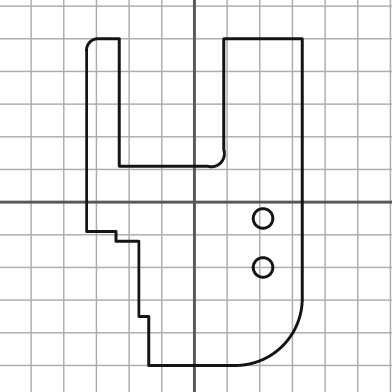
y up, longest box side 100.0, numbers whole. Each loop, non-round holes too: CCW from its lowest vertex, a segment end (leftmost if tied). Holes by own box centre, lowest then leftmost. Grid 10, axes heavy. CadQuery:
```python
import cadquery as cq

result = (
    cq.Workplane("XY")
    .moveTo(-14.0, -50.0)
    .lineTo(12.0, -50.0)
    .threePointArc((27.0, -44.0), (33.0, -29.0))
    .lineTo(33.0, 50.0)
    .lineTo(9.0, 50.0)
    .lineTo(9.0, 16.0)
    .threePointArc((8.0, 12.0), (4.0, 11.0))
    .lineTo(-23.0, 11.0)
    .lineTo(-23.0, 50.0)
    .lineTo(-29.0, 50.0)
    .threePointArc((-32.0, 49.0), (-33.0, 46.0))
    .lineTo(-33.0, -9.0)
    .lineTo(-24.0, -9.0)
    .lineTo(-24.0, -12.0)
    .lineTo(-17.0, -12.0)
    .lineTo(-17.0, -35.0)
    .lineTo(-14.0, -35.0)
    .close()
    .moveTo(21.0, -20.0)
    .circle(3.0)
    .moveTo(21.0, -5.0)
    .circle(3.0)
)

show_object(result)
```